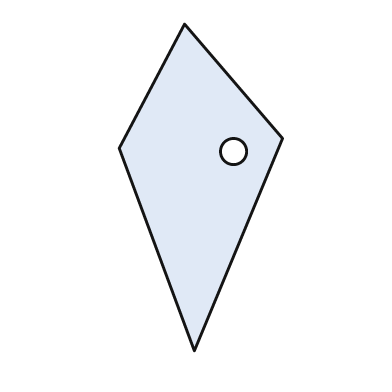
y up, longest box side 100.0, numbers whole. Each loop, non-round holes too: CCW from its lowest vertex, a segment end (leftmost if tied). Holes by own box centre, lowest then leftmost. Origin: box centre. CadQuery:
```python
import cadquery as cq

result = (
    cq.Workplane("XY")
    .moveTo(-2.0, -50.0)
    .lineTo(25.0, 15.0)
    .lineTo(-5.0, 50.0)
    .lineTo(-25.0, 12.0)
    .close()
    .moveTo(10.0, 11.0)
    .circle(4.0)
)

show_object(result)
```